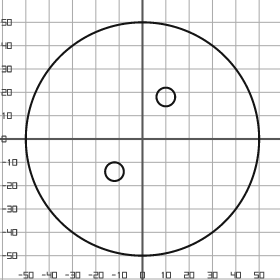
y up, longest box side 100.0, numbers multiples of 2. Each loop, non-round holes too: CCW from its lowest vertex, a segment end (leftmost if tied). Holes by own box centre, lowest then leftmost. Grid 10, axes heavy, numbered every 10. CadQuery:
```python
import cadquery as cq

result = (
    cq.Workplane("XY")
    .moveTo(0.0, 0.0)
    .circle(50.0)
    .moveTo(-12.0, -14.0)
    .circle(4.0)
    .moveTo(10.0, 18.0)
    .circle(4.0)
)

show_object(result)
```